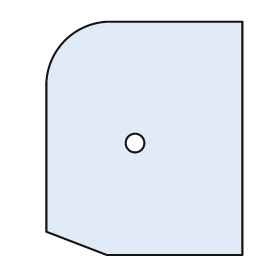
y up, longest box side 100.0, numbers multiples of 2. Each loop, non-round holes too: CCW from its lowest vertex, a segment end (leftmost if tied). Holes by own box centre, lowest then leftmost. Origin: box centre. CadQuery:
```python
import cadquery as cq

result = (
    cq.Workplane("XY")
    .moveTo(-16.0, -50.0)
    .lineTo(42.0, -50.0)
    .lineTo(42.0, 50.0)
    .lineTo(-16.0, 50.0)
    .threePointArc((-34.0, 42.0), (-42.0, 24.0))
    .lineTo(-42.0, -40.0)
    .close()
    .moveTo(-4.0, -2.0)
    .circle(4.0)
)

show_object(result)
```